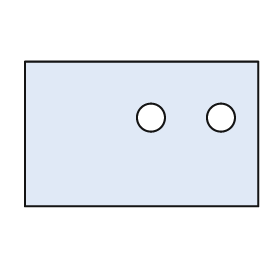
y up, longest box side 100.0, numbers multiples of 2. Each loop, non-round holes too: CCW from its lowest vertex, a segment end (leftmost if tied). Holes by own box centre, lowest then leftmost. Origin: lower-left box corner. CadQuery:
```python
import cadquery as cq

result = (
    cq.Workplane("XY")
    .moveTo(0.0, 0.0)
    .lineTo(100.0, 0.0)
    .lineTo(100.0, 62.0)
    .lineTo(0.0, 62.0)
    .close()
    .moveTo(54.0, 38.0)
    .circle(6.0)
    .moveTo(84.0, 38.0)
    .circle(6.0)
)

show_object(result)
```